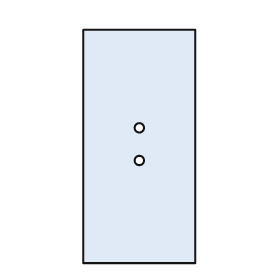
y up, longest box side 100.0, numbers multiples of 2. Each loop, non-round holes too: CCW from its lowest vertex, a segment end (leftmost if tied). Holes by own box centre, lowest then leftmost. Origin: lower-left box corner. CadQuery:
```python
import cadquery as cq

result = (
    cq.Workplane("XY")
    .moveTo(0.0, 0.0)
    .lineTo(48.0, 0.0)
    .lineTo(48.0, 100.0)
    .lineTo(0.0, 100.0)
    .close()
    .moveTo(24.0, 44.0)
    .circle(2.0)
    .moveTo(24.0, 58.0)
    .circle(2.0)
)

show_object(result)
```